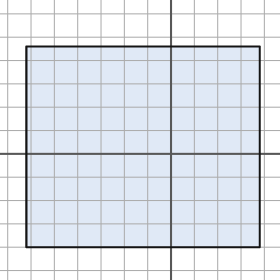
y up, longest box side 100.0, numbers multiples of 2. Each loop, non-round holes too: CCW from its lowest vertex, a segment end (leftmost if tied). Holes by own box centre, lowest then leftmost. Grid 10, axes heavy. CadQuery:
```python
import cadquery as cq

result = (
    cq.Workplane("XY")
    .moveTo(-62.0, -40.0)
    .lineTo(38.0, -40.0)
    .lineTo(38.0, 46.0)
    .lineTo(-62.0, 46.0)
    .close()
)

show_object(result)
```